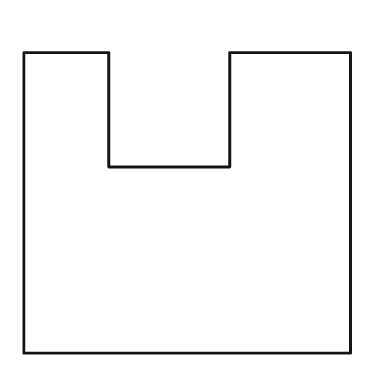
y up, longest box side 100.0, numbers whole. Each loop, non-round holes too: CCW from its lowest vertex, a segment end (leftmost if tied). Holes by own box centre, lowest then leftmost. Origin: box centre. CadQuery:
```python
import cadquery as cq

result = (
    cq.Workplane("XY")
    .moveTo(-50.0, -46.0)
    .lineTo(50.0, -46.0)
    .lineTo(50.0, 46.0)
    .lineTo(13.0, 46.0)
    .lineTo(13.0, 11.0)
    .lineTo(-24.0, 11.0)
    .lineTo(-24.0, 46.0)
    .lineTo(-50.0, 46.0)
    .close()
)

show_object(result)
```